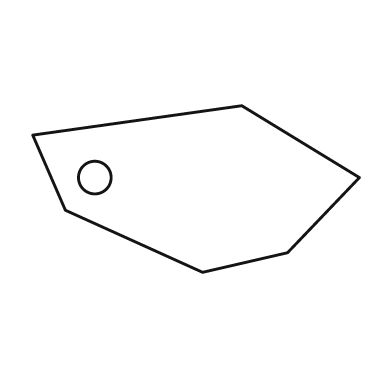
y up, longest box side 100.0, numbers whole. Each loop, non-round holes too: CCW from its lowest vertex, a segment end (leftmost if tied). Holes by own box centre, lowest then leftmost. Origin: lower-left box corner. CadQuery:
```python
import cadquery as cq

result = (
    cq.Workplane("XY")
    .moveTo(52.0, 0.0)
    .lineTo(78.0, 6.0)
    .lineTo(100.0, 29.0)
    .lineTo(64.0, 51.0)
    .lineTo(0.0, 42.0)
    .lineTo(10.0, 19.0)
    .close()
    .moveTo(19.0, 29.0)
    .circle(5.0)
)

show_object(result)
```